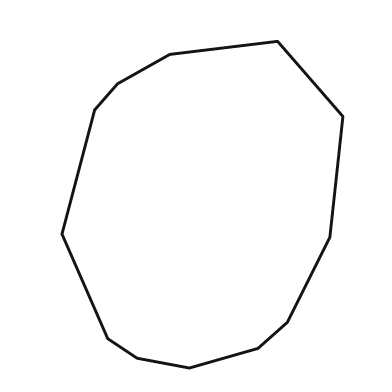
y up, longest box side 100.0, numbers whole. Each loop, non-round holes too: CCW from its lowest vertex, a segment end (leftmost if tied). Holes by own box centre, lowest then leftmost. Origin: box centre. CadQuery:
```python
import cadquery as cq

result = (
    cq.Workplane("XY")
    .moveTo(-4.0, -50.0)
    .lineTo(17.0, -44.0)
    .lineTo(26.0, -36.0)
    .lineTo(39.0, -10.0)
    .lineTo(43.0, 27.0)
    .lineTo(23.0, 50.0)
    .lineTo(-10.0, 46.0)
    .lineTo(-26.0, 37.0)
    .lineTo(-33.0, 29.0)
    .lineTo(-43.0, -9.0)
    .lineTo(-29.0, -41.0)
    .lineTo(-20.0, -47.0)
    .close()
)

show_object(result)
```